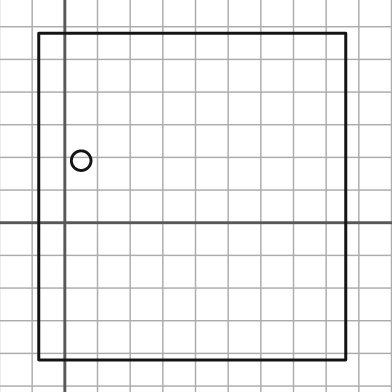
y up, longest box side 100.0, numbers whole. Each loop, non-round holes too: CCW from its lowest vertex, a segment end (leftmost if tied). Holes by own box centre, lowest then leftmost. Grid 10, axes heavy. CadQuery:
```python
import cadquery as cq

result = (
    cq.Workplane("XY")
    .moveTo(-8.0, -42.0)
    .lineTo(86.0, -42.0)
    .lineTo(86.0, 58.0)
    .lineTo(-8.0, 58.0)
    .close()
    .moveTo(5.0, 19.0)
    .circle(3.0)
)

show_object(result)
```